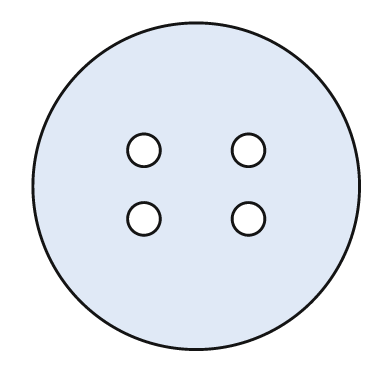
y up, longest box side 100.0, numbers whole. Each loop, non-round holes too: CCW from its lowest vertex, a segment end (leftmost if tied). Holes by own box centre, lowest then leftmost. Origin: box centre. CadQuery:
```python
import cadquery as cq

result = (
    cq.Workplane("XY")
    .moveTo(0.0, 0.0)
    .circle(50.0)
    .moveTo(-16.0, -10.0)
    .circle(5.0)
    .moveTo(16.0, -10.0)
    .circle(5.0)
    .moveTo(-16.0, 11.0)
    .circle(5.0)
    .moveTo(16.0, 11.0)
    .circle(5.0)
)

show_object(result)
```